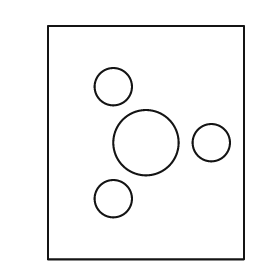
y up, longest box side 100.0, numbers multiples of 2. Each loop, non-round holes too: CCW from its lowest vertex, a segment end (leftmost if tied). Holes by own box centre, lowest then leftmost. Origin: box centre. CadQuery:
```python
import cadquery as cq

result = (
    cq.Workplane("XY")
    .moveTo(-42.0, -50.0)
    .lineTo(42.0, -50.0)
    .lineTo(42.0, 50.0)
    .lineTo(-42.0, 50.0)
    .close()
    .moveTo(-14.0, -24.0)
    .circle(8.0)
    .moveTo(0.0, 0.0)
    .circle(14.0)
    .moveTo(28.0, 0.0)
    .circle(8.0)
    .moveTo(-14.0, 24.0)
    .circle(8.0)
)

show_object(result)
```